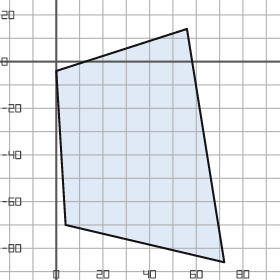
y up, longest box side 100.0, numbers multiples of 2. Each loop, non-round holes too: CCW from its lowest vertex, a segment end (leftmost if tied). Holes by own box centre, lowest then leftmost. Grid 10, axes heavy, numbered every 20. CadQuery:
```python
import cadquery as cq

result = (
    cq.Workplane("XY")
    .moveTo(72.0, -86.0)
    .lineTo(56.0, 14.0)
    .lineTo(0.0, -4.0)
    .lineTo(4.0, -70.0)
    .close()
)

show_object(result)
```